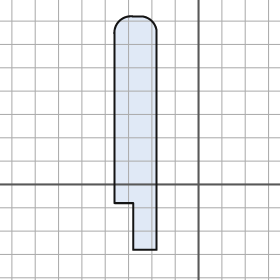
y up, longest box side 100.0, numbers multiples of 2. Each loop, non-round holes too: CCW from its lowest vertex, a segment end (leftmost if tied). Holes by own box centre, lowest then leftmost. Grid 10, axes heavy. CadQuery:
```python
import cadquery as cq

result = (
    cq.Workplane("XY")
    .moveTo(-28.0, -28.0)
    .lineTo(-18.0, -28.0)
    .lineTo(-18.0, 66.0)
    .threePointArc((-20.0, 70.0), (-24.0, 72.0))
    .lineTo(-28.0, 72.0)
    .threePointArc((-34.0, 70.0), (-36.0, 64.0))
    .lineTo(-36.0, -8.0)
    .lineTo(-28.0, -8.0)
    .close()
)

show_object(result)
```